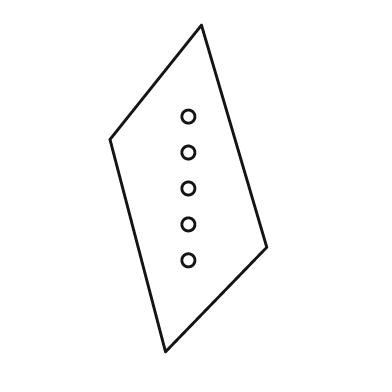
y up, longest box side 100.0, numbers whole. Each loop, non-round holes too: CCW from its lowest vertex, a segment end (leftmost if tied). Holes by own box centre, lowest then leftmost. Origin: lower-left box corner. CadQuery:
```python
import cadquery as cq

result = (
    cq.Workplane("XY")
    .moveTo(17.0, 0.0)
    .lineTo(48.0, 32.0)
    .lineTo(28.0, 100.0)
    .lineTo(0.0, 65.0)
    .close()
    .moveTo(24.0, 28.0)
    .circle(2.0)
    .moveTo(24.0, 39.0)
    .circle(2.0)
    .moveTo(24.0, 50.0)
    .circle(2.0)
    .moveTo(24.0, 61.0)
    .circle(2.0)
    .moveTo(24.0, 72.0)
    .circle(2.0)
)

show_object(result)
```